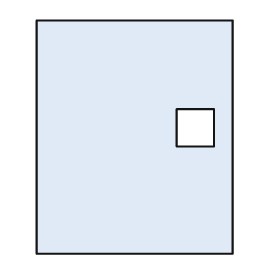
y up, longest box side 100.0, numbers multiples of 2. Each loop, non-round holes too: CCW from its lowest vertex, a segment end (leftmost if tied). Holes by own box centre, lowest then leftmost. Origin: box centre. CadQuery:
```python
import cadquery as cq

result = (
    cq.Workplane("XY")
    .moveTo(-42.0, -50.0)
    .lineTo(42.0, -50.0)
    .lineTo(42.0, 50.0)
    .lineTo(-42.0, 50.0)
    .close()
    .moveTo(18.0, -4.0)
    .lineTo(34.0, -4.0)
    .lineTo(34.0, 12.0)
    .lineTo(18.0, 12.0)
    .close()
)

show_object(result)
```